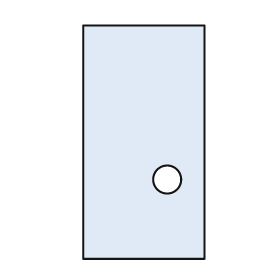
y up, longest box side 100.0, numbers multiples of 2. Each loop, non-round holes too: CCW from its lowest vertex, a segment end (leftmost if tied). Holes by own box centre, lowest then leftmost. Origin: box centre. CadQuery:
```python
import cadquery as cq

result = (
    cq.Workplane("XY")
    .moveTo(-26.0, -50.0)
    .lineTo(26.0, -50.0)
    .lineTo(26.0, 50.0)
    .lineTo(-26.0, 50.0)
    .close()
    .moveTo(10.0, -16.0)
    .circle(6.0)
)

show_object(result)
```